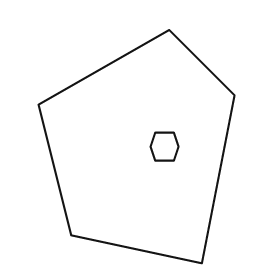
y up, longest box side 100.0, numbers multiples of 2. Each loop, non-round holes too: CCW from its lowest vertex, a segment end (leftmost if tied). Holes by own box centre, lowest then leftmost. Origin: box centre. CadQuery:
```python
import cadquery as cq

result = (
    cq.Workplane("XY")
    .moveTo(28.0, -50.0)
    .lineTo(42.0, 22.0)
    .lineTo(14.0, 50.0)
    .lineTo(-42.0, 18.0)
    .lineTo(-28.0, -38.0)
    .close()
    .moveTo(8.0, -6.0)
    .lineTo(16.0, -6.0)
    .lineTo(18.0, 0.0)
    .lineTo(16.0, 6.0)
    .lineTo(8.0, 6.0)
    .lineTo(6.0, 0.0)
    .close()
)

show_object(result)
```